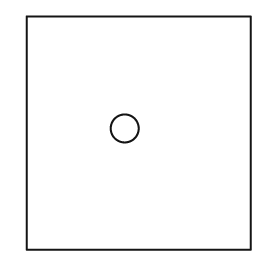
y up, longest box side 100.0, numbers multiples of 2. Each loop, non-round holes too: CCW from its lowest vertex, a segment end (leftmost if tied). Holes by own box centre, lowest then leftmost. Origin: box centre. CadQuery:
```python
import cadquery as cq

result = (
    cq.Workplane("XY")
    .moveTo(-48.0, -50.0)
    .lineTo(48.0, -50.0)
    .lineTo(48.0, 50.0)
    .lineTo(-48.0, 50.0)
    .close()
    .moveTo(-6.0, 2.0)
    .circle(6.0)
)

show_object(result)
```